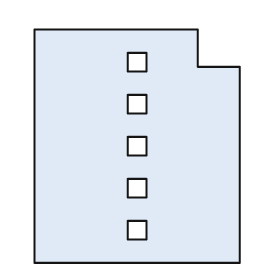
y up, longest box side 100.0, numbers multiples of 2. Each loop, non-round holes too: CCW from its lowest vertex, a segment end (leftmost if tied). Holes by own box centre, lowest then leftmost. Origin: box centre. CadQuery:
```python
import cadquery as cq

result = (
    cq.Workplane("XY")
    .moveTo(-44.0, -50.0)
    .lineTo(44.0, -50.0)
    .lineTo(44.0, 34.0)
    .lineTo(26.0, 34.0)
    .lineTo(26.0, 50.0)
    .lineTo(-44.0, 50.0)
    .close()
    .moveTo(-4.0, -40.0)
    .lineTo(4.0, -40.0)
    .lineTo(4.0, -32.0)
    .lineTo(-4.0, -32.0)
    .close()
    .moveTo(-4.0, -22.0)
    .lineTo(4.0, -22.0)
    .lineTo(4.0, -14.0)
    .lineTo(-4.0, -14.0)
    .close()
    .moveTo(-4.0, -4.0)
    .lineTo(4.0, -4.0)
    .lineTo(4.0, 4.0)
    .lineTo(-4.0, 4.0)
    .close()
    .moveTo(-4.0, 14.0)
    .lineTo(4.0, 14.0)
    .lineTo(4.0, 22.0)
    .lineTo(-4.0, 22.0)
    .close()
    .moveTo(-4.0, 32.0)
    .lineTo(4.0, 32.0)
    .lineTo(4.0, 40.0)
    .lineTo(-4.0, 40.0)
    .close()
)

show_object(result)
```